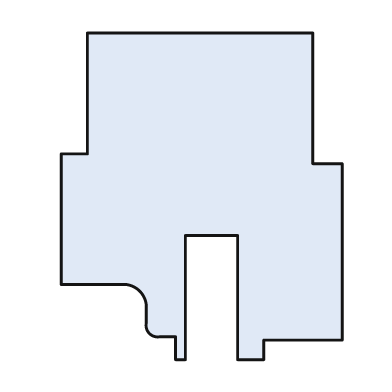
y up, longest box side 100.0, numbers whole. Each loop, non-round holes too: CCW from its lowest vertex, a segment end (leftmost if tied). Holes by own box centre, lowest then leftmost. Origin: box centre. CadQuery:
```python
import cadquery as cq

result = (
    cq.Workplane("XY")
    .moveTo(-8.0, -50.0)
    .lineTo(-5.0, -50.0)
    .lineTo(-5.0, -12.0)
    .lineTo(11.0, -12.0)
    .lineTo(11.0, -50.0)
    .lineTo(19.0, -50.0)
    .lineTo(19.0, -44.0)
    .lineTo(43.0, -44.0)
    .lineTo(43.0, 10.0)
    .lineTo(34.0, 10.0)
    .lineTo(34.0, 50.0)
    .lineTo(-35.0, 50.0)
    .lineTo(-35.0, 13.0)
    .lineTo(-43.0, 13.0)
    .lineTo(-43.0, -27.0)
    .lineTo(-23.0, -27.0)
    .threePointArc((-19.0, -29.0), (-17.0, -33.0))
    .lineTo(-17.0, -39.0)
    .threePointArc((-16.0, -42.0), (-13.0, -43.0))
    .lineTo(-8.0, -43.0)
    .close()
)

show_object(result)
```